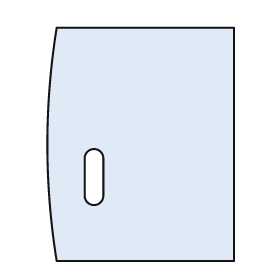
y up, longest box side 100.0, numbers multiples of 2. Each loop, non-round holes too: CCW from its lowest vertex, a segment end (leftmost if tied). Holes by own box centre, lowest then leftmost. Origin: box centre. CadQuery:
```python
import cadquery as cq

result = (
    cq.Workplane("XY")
    .moveTo(-36.0, -50.0)
    .lineTo(40.0, -50.0)
    .lineTo(40.0, 50.0)
    .lineTo(-36.0, 50.0)
    .threePointArc((-40.0, 0.0), (-36.0, -50.0))
    .close()
    .moveTo(-24.0, -22.0)
    .threePointArc((-20.0, -26.0), (-16.0, -22.0))
    .lineTo(-16.0, -6.0)
    .threePointArc((-20.0, -2.0), (-24.0, -6.0))
    .close()
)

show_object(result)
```